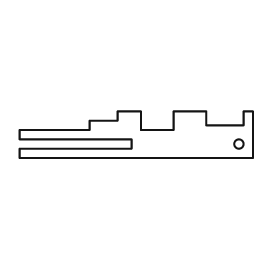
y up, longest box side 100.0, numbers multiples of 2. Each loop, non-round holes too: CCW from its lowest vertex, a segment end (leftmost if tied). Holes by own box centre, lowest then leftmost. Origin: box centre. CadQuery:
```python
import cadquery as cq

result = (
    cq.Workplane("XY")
    .moveTo(-50.0, -10.0)
    .lineTo(50.0, -10.0)
    .lineTo(50.0, 10.0)
    .lineTo(46.0, 10.0)
    .lineTo(46.0, 4.0)
    .lineTo(30.0, 4.0)
    .lineTo(30.0, 10.0)
    .lineTo(16.0, 10.0)
    .lineTo(16.0, 2.0)
    .lineTo(2.0, 2.0)
    .lineTo(2.0, 10.0)
    .lineTo(-8.0, 10.0)
    .lineTo(-8.0, 6.0)
    .lineTo(-20.0, 6.0)
    .lineTo(-20.0, 2.0)
    .lineTo(-50.0, 2.0)
    .lineTo(-50.0, -2.0)
    .lineTo(-2.0, -2.0)
    .lineTo(-2.0, -6.0)
    .lineTo(-50.0, -6.0)
    .close()
    .moveTo(44.0, -4.0)
    .circle(2.0)
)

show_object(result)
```